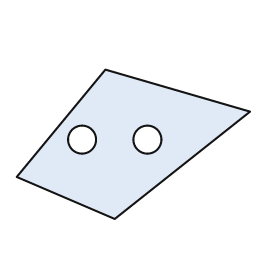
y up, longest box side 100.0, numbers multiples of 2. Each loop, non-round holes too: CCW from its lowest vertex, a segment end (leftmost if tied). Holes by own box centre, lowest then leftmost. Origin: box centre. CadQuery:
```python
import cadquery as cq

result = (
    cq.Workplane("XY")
    .moveTo(-8.0, -32.0)
    .lineTo(50.0, 14.0)
    .lineTo(-12.0, 32.0)
    .lineTo(-50.0, -14.0)
    .close()
    .moveTo(-22.0, 2.0)
    .circle(6.0)
    .moveTo(6.0, 2.0)
    .circle(6.0)
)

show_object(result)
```